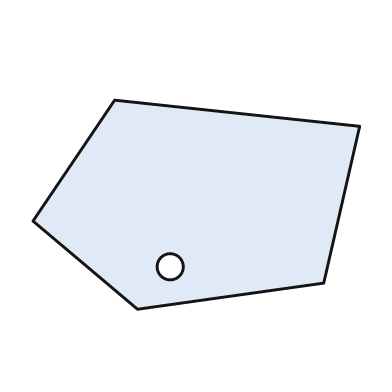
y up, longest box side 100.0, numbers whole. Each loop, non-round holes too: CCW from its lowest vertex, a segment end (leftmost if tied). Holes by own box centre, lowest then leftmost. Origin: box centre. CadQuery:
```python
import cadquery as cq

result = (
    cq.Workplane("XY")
    .moveTo(-18.0, -32.0)
    .lineTo(39.0, -24.0)
    .lineTo(50.0, 24.0)
    .lineTo(-25.0, 32.0)
    .lineTo(-50.0, -5.0)
    .close()
    .moveTo(-8.0, -19.0)
    .circle(4.0)
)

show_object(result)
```